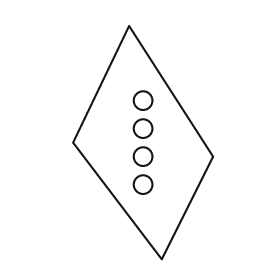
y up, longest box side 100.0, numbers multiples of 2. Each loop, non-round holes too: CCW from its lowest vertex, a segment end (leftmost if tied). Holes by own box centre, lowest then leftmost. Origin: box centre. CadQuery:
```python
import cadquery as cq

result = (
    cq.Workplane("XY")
    .moveTo(8.0, -50.0)
    .lineTo(30.0, -6.0)
    .lineTo(-6.0, 50.0)
    .lineTo(-30.0, 0.0)
    .close()
    .moveTo(0.0, -18.0)
    .circle(4.0)
    .moveTo(0.0, -6.0)
    .circle(4.0)
    .moveTo(0.0, 6.0)
    .circle(4.0)
    .moveTo(0.0, 18.0)
    .circle(4.0)
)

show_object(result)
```